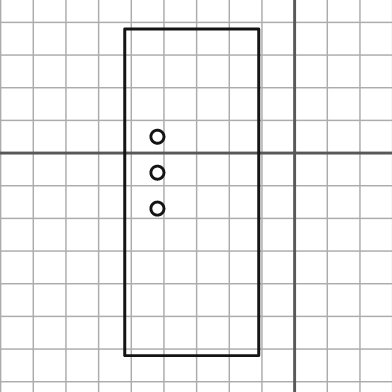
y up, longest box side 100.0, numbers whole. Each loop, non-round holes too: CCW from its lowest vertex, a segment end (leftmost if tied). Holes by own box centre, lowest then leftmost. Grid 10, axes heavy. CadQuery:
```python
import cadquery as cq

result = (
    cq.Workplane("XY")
    .moveTo(-52.0, -62.0)
    .lineTo(-11.0, -62.0)
    .lineTo(-11.0, 38.0)
    .lineTo(-52.0, 38.0)
    .close()
    .moveTo(-42.0, -17.0)
    .circle(2.0)
    .moveTo(-42.0, -6.0)
    .circle(2.0)
    .moveTo(-42.0, 5.0)
    .circle(2.0)
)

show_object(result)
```